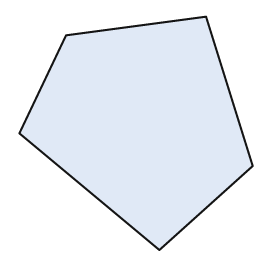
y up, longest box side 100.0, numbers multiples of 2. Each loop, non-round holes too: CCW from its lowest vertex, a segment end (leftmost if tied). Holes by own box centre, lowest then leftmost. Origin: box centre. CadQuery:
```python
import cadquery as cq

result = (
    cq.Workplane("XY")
    .moveTo(10.0, -50.0)
    .lineTo(50.0, -14.0)
    .lineTo(30.0, 50.0)
    .lineTo(-30.0, 42.0)
    .lineTo(-50.0, 0.0)
    .close()
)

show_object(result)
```